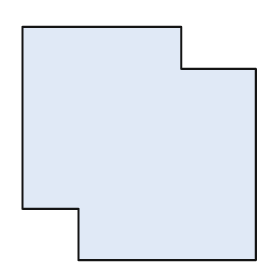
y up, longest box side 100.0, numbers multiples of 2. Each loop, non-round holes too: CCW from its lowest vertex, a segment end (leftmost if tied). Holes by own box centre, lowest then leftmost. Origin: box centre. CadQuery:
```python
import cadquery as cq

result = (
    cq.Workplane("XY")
    .moveTo(-26.0, -50.0)
    .lineTo(50.0, -50.0)
    .lineTo(50.0, 32.0)
    .lineTo(18.0, 32.0)
    .lineTo(18.0, 50.0)
    .lineTo(-50.0, 50.0)
    .lineTo(-50.0, -28.0)
    .lineTo(-26.0, -28.0)
    .close()
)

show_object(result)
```